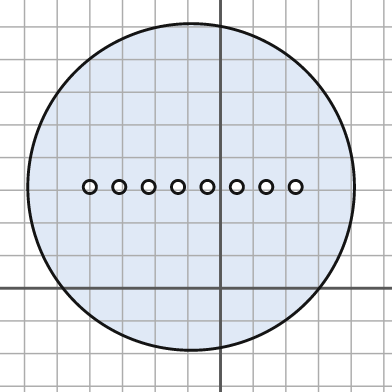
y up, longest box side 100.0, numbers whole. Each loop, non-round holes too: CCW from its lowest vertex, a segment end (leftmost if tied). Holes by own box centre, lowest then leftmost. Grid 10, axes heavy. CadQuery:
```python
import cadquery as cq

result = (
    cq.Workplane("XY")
    .moveTo(-9.0, 31.0)
    .circle(50.0)
    .moveTo(-40.0, 31.0)
    .circle(2.0)
    .moveTo(-31.0, 31.0)
    .circle(2.0)
    .moveTo(-22.0, 31.0)
    .circle(2.0)
    .moveTo(-13.0, 31.0)
    .circle(2.0)
    .moveTo(-4.0, 31.0)
    .circle(2.0)
    .moveTo(5.0, 31.0)
    .circle(2.0)
    .moveTo(14.0, 31.0)
    .circle(2.0)
    .moveTo(23.0, 31.0)
    .circle(2.0)
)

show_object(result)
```